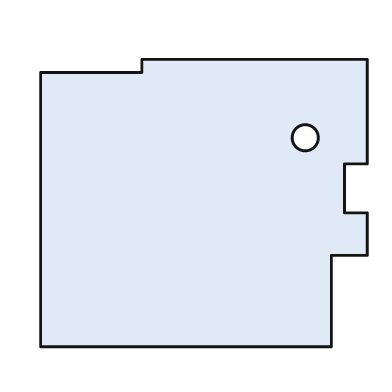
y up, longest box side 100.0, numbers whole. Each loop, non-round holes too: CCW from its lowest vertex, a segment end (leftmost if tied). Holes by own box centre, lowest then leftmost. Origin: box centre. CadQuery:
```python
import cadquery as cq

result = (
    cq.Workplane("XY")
    .moveTo(-50.0, -44.0)
    .lineTo(39.0, -44.0)
    .lineTo(39.0, -16.0)
    .lineTo(50.0, -16.0)
    .lineTo(50.0, -3.0)
    .lineTo(43.0, -3.0)
    .lineTo(43.0, 12.0)
    .lineTo(50.0, 12.0)
    .lineTo(50.0, 44.0)
    .lineTo(-19.0, 44.0)
    .lineTo(-19.0, 40.0)
    .lineTo(-50.0, 40.0)
    .close()
    .moveTo(31.0, 20.0)
    .circle(4.0)
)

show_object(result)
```